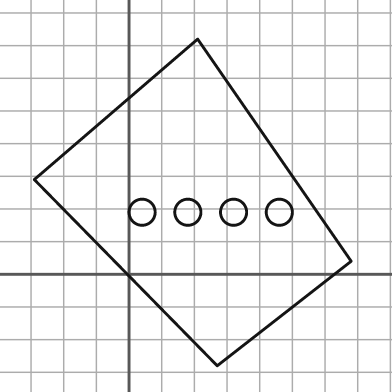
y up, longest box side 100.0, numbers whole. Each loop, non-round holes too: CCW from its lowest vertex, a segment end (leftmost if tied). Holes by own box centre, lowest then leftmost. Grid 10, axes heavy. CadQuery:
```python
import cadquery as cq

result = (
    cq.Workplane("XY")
    .moveTo(27.0, -28.0)
    .lineTo(68.0, 4.0)
    .lineTo(21.0, 72.0)
    .lineTo(-29.0, 29.0)
    .close()
    .moveTo(4.0, 19.0)
    .circle(4.0)
    .moveTo(18.0, 19.0)
    .circle(4.0)
    .moveTo(32.0, 19.0)
    .circle(4.0)
    .moveTo(46.0, 19.0)
    .circle(4.0)
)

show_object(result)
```